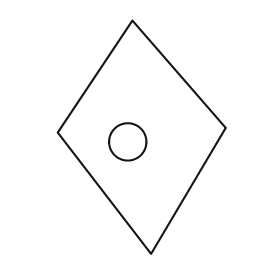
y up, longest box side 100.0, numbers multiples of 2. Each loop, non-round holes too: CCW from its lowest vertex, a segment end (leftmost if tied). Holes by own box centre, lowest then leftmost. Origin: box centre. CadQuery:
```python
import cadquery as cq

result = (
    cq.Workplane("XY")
    .moveTo(4.0, -50.0)
    .lineTo(36.0, 4.0)
    .lineTo(-4.0, 50.0)
    .lineTo(-36.0, 2.0)
    .close()
    .moveTo(-6.0, -2.0)
    .circle(8.0)
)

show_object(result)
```